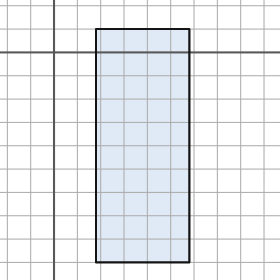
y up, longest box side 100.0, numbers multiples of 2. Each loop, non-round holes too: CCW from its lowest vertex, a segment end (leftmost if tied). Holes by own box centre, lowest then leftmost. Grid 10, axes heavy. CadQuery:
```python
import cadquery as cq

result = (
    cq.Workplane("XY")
    .moveTo(18.0, -90.0)
    .lineTo(58.0, -90.0)
    .lineTo(58.0, 10.0)
    .lineTo(18.0, 10.0)
    .close()
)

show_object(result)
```